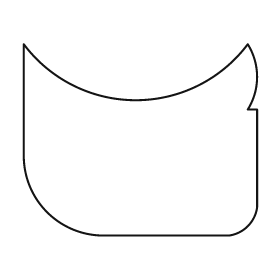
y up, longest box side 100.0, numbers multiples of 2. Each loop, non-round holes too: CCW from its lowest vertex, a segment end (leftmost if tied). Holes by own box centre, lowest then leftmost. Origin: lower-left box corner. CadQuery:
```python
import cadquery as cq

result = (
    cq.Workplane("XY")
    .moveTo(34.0, 0.0)
    .lineTo(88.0, 0.0)
    .threePointArc((96.0, 4.0), (100.0, 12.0))
    .lineTo(100.0, 54.0)
    .lineTo(96.0, 54.0)
    .threePointArc((100.0, 68.0), (96.0, 82.0))
    .threePointArc((48.0, 58.0), (0.0, 82.0))
    .lineTo(0.0, 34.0)
    .threePointArc((10.0, 10.0), (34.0, 0.0))
    .close()
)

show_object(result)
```